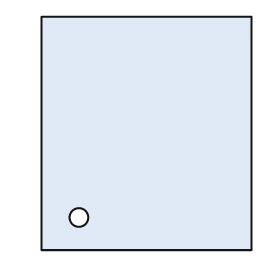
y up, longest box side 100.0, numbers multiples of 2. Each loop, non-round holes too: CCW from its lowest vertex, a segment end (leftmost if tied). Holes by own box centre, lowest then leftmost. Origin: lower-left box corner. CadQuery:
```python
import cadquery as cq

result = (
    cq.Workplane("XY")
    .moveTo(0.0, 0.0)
    .lineTo(90.0, 0.0)
    .lineTo(90.0, 100.0)
    .lineTo(0.0, 100.0)
    .close()
    .moveTo(16.0, 14.0)
    .circle(4.0)
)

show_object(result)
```